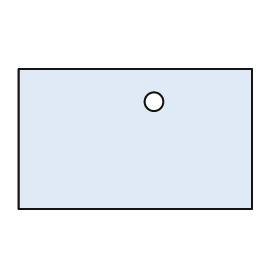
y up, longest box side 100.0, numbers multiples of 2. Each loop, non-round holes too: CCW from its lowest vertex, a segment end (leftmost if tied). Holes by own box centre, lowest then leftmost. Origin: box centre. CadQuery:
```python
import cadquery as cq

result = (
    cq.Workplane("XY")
    .moveTo(-50.0, -30.0)
    .lineTo(50.0, -30.0)
    .lineTo(50.0, 30.0)
    .lineTo(-50.0, 30.0)
    .close()
    .moveTo(8.0, 16.0)
    .circle(4.0)
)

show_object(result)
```